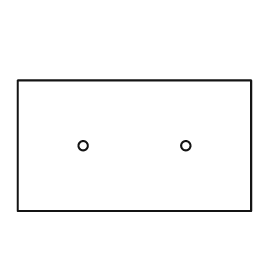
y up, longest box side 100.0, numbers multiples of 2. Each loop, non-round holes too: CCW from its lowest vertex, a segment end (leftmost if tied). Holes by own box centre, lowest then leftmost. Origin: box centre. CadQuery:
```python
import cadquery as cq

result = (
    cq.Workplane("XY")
    .moveTo(-50.0, -28.0)
    .lineTo(50.0, -28.0)
    .lineTo(50.0, 28.0)
    .lineTo(-50.0, 28.0)
    .close()
    .moveTo(-22.0, 0.0)
    .circle(2.0)
    .moveTo(22.0, 0.0)
    .circle(2.0)
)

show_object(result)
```